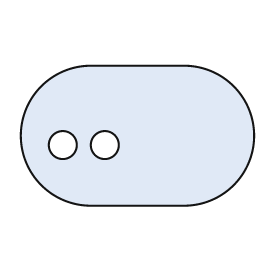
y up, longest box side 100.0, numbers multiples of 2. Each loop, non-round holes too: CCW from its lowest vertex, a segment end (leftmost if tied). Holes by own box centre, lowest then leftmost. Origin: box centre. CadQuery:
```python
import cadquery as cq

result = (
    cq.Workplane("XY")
    .moveTo(-20.0, -30.0)
    .lineTo(20.0, -30.0)
    .threePointArc((50.0, 0.0), (20.0, 30.0))
    .lineTo(-20.0, 30.0)
    .threePointArc((-50.0, 0.0), (-20.0, -30.0))
    .close()
    .moveTo(-32.0, -4.0)
    .circle(6.0)
    .moveTo(-14.0, -4.0)
    .circle(6.0)
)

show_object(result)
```